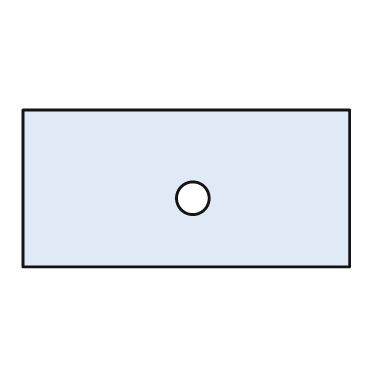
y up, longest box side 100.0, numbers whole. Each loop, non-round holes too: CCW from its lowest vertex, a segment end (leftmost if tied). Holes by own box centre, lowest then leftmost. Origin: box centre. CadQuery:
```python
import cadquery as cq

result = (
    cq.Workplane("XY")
    .moveTo(-50.0, -24.0)
    .lineTo(50.0, -24.0)
    .lineTo(50.0, 24.0)
    .lineTo(-50.0, 24.0)
    .close()
    .moveTo(2.0, -3.0)
    .circle(5.0)
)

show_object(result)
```